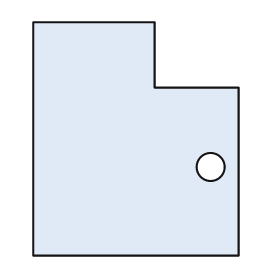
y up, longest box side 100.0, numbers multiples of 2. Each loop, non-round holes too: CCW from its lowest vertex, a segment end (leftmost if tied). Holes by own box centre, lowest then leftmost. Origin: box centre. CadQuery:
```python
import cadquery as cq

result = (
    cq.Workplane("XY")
    .moveTo(-44.0, -50.0)
    .lineTo(44.0, -50.0)
    .lineTo(44.0, 22.0)
    .lineTo(8.0, 22.0)
    .lineTo(8.0, 50.0)
    .lineTo(-44.0, 50.0)
    .close()
    .moveTo(32.0, -12.0)
    .circle(6.0)
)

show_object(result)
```